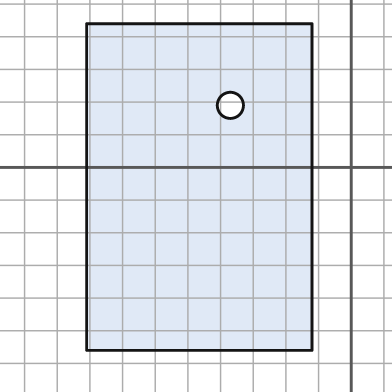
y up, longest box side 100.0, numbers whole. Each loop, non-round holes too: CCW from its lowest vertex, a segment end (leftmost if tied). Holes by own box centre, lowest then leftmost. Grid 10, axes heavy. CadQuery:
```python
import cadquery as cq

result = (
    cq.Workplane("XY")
    .moveTo(-81.0, -56.0)
    .lineTo(-12.0, -56.0)
    .lineTo(-12.0, 44.0)
    .lineTo(-81.0, 44.0)
    .close()
    .moveTo(-37.0, 19.0)
    .circle(4.0)
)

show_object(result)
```